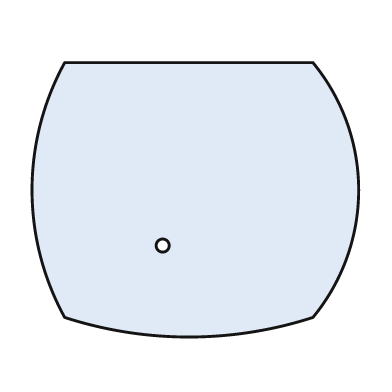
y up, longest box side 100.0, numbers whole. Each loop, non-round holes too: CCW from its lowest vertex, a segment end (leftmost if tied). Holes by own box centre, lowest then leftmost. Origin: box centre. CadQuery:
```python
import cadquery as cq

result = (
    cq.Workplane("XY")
    .moveTo(-40.0, -36.0)
    .threePointArc((-2.0, -42.0), (36.0, -36.0))
    .threePointArc((50.0, 3.0), (36.0, 42.0))
    .lineTo(-40.0, 42.0)
    .threePointArc((-50.0, 3.0), (-40.0, -36.0))
    .close()
    .moveTo(-10.0, -14.0)
    .circle(2.0)
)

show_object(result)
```